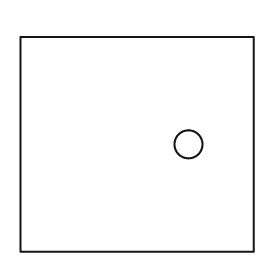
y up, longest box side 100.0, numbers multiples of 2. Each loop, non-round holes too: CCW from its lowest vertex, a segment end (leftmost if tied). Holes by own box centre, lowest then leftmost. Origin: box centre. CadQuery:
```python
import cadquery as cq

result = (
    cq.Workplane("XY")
    .moveTo(-50.0, -46.0)
    .lineTo(50.0, -46.0)
    .lineTo(50.0, 46.0)
    .lineTo(-50.0, 46.0)
    .close()
    .moveTo(22.0, 0.0)
    .circle(6.0)
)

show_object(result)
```